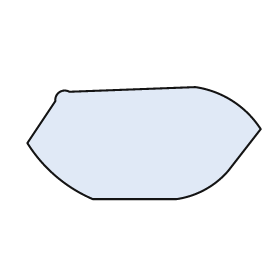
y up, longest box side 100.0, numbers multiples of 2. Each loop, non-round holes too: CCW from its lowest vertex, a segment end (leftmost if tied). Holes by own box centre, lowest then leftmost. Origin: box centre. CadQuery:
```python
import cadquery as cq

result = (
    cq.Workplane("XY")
    .moveTo(-22.0, -24.0)
    .lineTo(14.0, -24.0)
    .threePointArc((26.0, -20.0), (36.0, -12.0))
    .lineTo(50.0, 6.0)
    .threePointArc((38.0, 18.0), (22.0, 24.0))
    .lineTo(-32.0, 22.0)
    .threePointArc((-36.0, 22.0), (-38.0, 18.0))
    .lineTo(-50.0, 0.0)
    .threePointArc((-38.0, -14.0), (-22.0, -24.0))
    .close()
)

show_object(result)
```